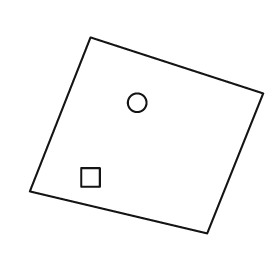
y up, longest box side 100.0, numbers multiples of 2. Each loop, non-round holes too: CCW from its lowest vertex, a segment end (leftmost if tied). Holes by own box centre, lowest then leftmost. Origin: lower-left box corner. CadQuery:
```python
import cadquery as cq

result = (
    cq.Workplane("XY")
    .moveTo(76.0, 0.0)
    .lineTo(100.0, 60.0)
    .lineTo(26.0, 84.0)
    .lineTo(0.0, 18.0)
    .close()
    .moveTo(22.0, 20.0)
    .lineTo(30.0, 20.0)
    .lineTo(30.0, 28.0)
    .lineTo(22.0, 28.0)
    .close()
    .moveTo(46.0, 56.0)
    .circle(4.0)
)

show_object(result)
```